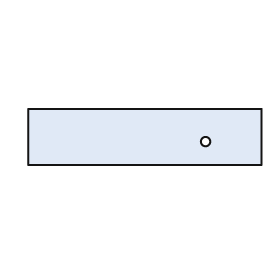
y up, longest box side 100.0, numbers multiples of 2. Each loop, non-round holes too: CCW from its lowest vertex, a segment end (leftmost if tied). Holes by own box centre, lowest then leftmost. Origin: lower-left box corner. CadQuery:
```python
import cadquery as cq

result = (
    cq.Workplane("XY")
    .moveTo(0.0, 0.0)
    .lineTo(100.0, 0.0)
    .lineTo(100.0, 24.0)
    .lineTo(0.0, 24.0)
    .close()
    .moveTo(76.0, 10.0)
    .circle(2.0)
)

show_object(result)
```